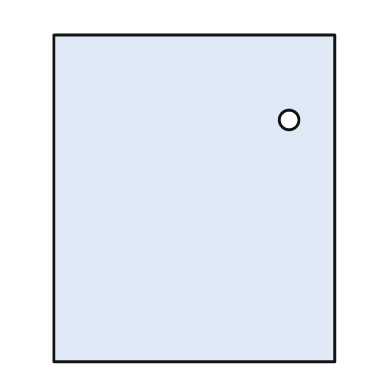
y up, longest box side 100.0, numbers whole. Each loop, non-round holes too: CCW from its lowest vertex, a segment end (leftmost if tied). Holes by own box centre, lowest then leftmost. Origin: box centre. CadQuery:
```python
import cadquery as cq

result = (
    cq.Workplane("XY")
    .moveTo(-43.0, -50.0)
    .lineTo(43.0, -50.0)
    .lineTo(43.0, 50.0)
    .lineTo(-43.0, 50.0)
    .close()
    .moveTo(29.0, 24.0)
    .circle(3.0)
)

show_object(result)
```